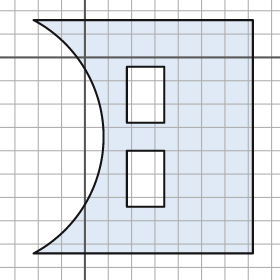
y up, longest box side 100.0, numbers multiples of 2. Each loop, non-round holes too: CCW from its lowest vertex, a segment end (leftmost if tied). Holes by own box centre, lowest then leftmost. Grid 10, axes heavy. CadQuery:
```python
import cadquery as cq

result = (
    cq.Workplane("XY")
    .moveTo(-22.0, -84.0)
    .lineTo(72.0, -84.0)
    .lineTo(72.0, 16.0)
    .lineTo(-22.0, 16.0)
    .threePointArc((8.0, -34.0), (-22.0, -84.0))
    .close()
    .moveTo(18.0, -64.0)
    .lineTo(34.0, -64.0)
    .lineTo(34.0, -40.0)
    .lineTo(18.0, -40.0)
    .close()
    .moveTo(18.0, -28.0)
    .lineTo(34.0, -28.0)
    .lineTo(34.0, -4.0)
    .lineTo(18.0, -4.0)
    .close()
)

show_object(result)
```